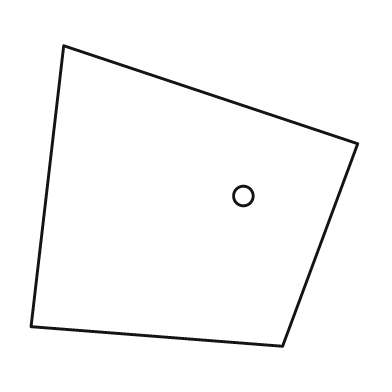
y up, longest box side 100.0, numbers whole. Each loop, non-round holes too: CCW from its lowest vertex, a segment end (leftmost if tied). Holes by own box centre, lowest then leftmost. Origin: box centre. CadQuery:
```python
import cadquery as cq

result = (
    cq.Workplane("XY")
    .moveTo(27.0, -46.0)
    .lineTo(50.0, 16.0)
    .lineTo(-40.0, 46.0)
    .lineTo(-50.0, -40.0)
    .close()
    .moveTo(15.0, 0.0)
    .circle(3.0)
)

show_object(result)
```